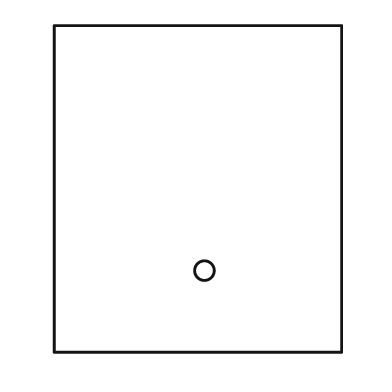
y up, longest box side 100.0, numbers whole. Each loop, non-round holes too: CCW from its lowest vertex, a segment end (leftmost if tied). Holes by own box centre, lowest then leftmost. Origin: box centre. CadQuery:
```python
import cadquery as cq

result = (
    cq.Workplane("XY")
    .moveTo(-44.0, -50.0)
    .lineTo(44.0, -50.0)
    .lineTo(44.0, 50.0)
    .lineTo(-44.0, 50.0)
    .close()
    .moveTo(2.0, -25.0)
    .circle(3.0)
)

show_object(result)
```